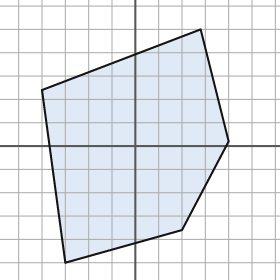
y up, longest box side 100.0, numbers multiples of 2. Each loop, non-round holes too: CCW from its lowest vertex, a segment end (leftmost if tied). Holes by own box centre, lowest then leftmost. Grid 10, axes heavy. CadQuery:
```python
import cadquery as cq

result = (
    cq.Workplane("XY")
    .moveTo(-30.0, -50.0)
    .lineTo(20.0, -36.0)
    .lineTo(40.0, 2.0)
    .lineTo(28.0, 50.0)
    .lineTo(-40.0, 24.0)
    .close()
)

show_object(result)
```